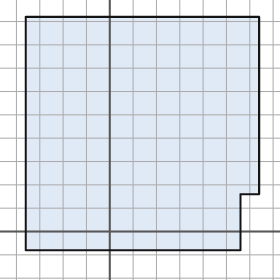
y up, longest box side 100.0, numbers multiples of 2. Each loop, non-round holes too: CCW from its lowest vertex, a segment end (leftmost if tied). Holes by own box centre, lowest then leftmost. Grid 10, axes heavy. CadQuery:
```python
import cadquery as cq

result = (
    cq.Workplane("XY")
    .moveTo(-36.0, -8.0)
    .lineTo(56.0, -8.0)
    .lineTo(56.0, 16.0)
    .lineTo(64.0, 16.0)
    .lineTo(64.0, 92.0)
    .lineTo(-36.0, 92.0)
    .close()
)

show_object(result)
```